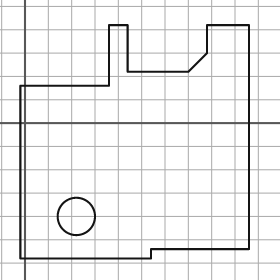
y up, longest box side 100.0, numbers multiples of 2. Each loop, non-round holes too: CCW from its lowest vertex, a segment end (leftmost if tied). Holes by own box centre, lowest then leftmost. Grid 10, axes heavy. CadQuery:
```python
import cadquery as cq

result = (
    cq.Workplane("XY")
    .moveTo(-2.0, -58.0)
    .lineTo(54.0, -58.0)
    .lineTo(54.0, -54.0)
    .lineTo(96.0, -54.0)
    .lineTo(96.0, 42.0)
    .lineTo(78.0, 42.0)
    .lineTo(78.0, 30.0)
    .lineTo(70.0, 22.0)
    .lineTo(44.0, 22.0)
    .lineTo(44.0, 42.0)
    .lineTo(36.0, 42.0)
    .lineTo(36.0, 16.0)
    .lineTo(-2.0, 16.0)
    .close()
    .moveTo(22.0, -40.0)
    .circle(8.0)
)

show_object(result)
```